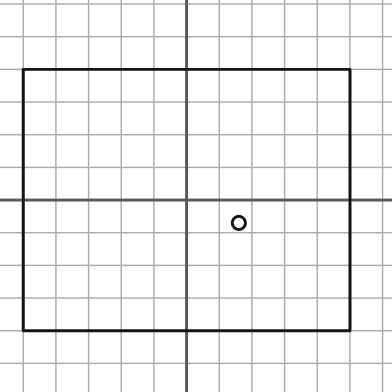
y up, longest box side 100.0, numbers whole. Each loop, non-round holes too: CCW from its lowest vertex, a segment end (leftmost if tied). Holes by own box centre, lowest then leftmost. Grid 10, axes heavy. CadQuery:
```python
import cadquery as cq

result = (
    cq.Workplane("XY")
    .moveTo(-50.0, -40.0)
    .lineTo(50.0, -40.0)
    .lineTo(50.0, 40.0)
    .lineTo(-50.0, 40.0)
    .close()
    .moveTo(16.0, -7.0)
    .circle(2.0)
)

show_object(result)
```